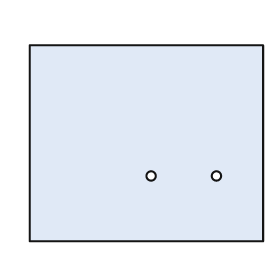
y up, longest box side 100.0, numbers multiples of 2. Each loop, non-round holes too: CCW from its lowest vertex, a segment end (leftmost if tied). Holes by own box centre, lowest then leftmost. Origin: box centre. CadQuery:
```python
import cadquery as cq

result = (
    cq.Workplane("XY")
    .moveTo(-50.0, -42.0)
    .lineTo(50.0, -42.0)
    .lineTo(50.0, 42.0)
    .lineTo(-50.0, 42.0)
    .close()
    .moveTo(2.0, -14.0)
    .circle(2.0)
    .moveTo(30.0, -14.0)
    .circle(2.0)
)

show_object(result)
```